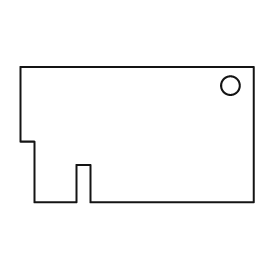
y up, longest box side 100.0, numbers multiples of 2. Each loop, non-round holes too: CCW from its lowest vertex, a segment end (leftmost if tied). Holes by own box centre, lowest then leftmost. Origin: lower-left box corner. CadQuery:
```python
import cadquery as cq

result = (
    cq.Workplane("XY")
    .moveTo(6.0, 0.0)
    .lineTo(24.0, 0.0)
    .lineTo(24.0, 16.0)
    .lineTo(30.0, 16.0)
    .lineTo(30.0, 0.0)
    .lineTo(100.0, 0.0)
    .lineTo(100.0, 58.0)
    .lineTo(0.0, 58.0)
    .lineTo(0.0, 26.0)
    .lineTo(6.0, 26.0)
    .close()
    .moveTo(90.0, 50.0)
    .circle(4.0)
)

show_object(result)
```